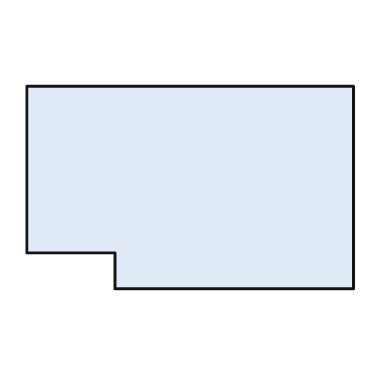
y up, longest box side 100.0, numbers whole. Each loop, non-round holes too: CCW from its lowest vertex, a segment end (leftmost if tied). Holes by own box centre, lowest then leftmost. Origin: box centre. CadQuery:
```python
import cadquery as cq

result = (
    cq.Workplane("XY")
    .moveTo(-23.0, -31.0)
    .lineTo(50.0, -31.0)
    .lineTo(50.0, 31.0)
    .lineTo(-50.0, 31.0)
    .lineTo(-50.0, -20.0)
    .lineTo(-23.0, -20.0)
    .close()
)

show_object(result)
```